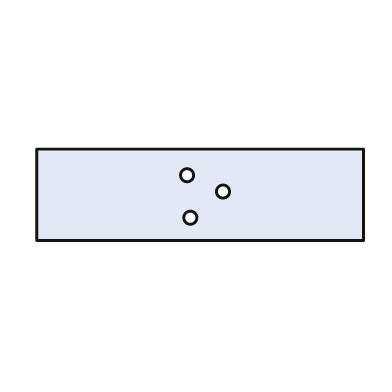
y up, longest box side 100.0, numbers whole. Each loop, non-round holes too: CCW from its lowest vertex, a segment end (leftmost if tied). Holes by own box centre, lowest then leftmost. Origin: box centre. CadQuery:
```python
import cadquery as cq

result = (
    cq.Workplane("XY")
    .moveTo(-50.0, -14.0)
    .lineTo(50.0, -14.0)
    .lineTo(50.0, 14.0)
    .lineTo(-50.0, 14.0)
    .close()
    .moveTo(-3.0, -7.0)
    .circle(2.0)
    .moveTo(7.0, 1.0)
    .circle(2.0)
    .moveTo(-4.0, 6.0)
    .circle(2.0)
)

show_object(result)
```